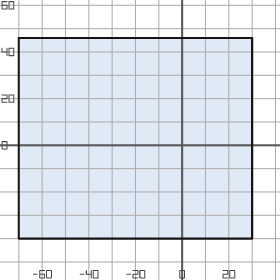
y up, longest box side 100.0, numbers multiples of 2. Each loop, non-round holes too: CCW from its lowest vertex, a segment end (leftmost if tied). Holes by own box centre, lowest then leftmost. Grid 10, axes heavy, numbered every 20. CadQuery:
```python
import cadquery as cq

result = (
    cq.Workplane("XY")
    .moveTo(-70.0, -40.0)
    .lineTo(30.0, -40.0)
    .lineTo(30.0, 46.0)
    .lineTo(-70.0, 46.0)
    .close()
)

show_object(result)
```